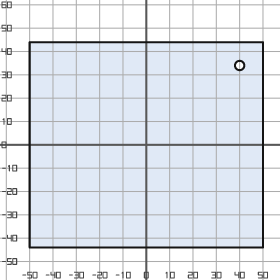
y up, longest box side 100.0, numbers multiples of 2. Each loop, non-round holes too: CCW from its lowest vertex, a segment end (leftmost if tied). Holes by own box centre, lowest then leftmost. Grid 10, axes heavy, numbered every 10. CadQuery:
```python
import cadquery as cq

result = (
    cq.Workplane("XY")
    .moveTo(-50.0, -44.0)
    .lineTo(50.0, -44.0)
    .lineTo(50.0, 44.0)
    .lineTo(-50.0, 44.0)
    .close()
    .moveTo(40.0, 34.0)
    .circle(2.0)
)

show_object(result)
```